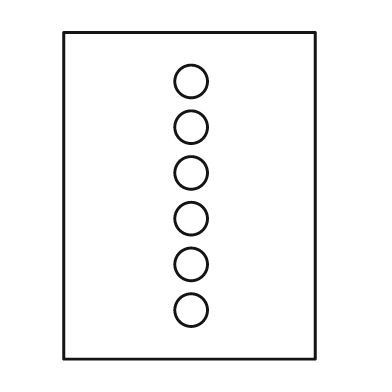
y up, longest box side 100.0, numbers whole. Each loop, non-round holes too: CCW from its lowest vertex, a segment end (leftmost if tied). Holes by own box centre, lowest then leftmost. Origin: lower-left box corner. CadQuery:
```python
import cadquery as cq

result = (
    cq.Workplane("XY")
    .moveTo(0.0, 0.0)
    .lineTo(77.0, 0.0)
    .lineTo(77.0, 100.0)
    .lineTo(0.0, 100.0)
    .close()
    .moveTo(39.0, 15.0)
    .circle(5.0)
    .moveTo(39.0, 29.0)
    .circle(5.0)
    .moveTo(39.0, 43.0)
    .circle(5.0)
    .moveTo(39.0, 57.0)
    .circle(5.0)
    .moveTo(39.0, 71.0)
    .circle(5.0)
    .moveTo(39.0, 85.0)
    .circle(5.0)
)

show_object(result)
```